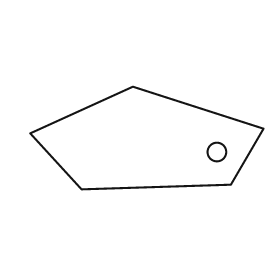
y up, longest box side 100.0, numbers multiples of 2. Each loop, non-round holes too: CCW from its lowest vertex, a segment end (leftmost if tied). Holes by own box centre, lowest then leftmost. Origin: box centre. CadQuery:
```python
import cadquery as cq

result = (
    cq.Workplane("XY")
    .moveTo(-28.0, -22.0)
    .lineTo(36.0, -20.0)
    .lineTo(50.0, 4.0)
    .lineTo(-6.0, 22.0)
    .lineTo(-50.0, 2.0)
    .close()
    .moveTo(30.0, -6.0)
    .circle(4.0)
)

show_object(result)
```